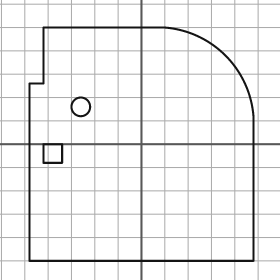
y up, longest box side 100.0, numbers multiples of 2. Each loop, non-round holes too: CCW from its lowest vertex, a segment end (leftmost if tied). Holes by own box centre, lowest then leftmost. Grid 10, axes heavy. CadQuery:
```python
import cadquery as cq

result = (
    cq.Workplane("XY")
    .moveTo(-48.0, -50.0)
    .lineTo(48.0, -50.0)
    .lineTo(48.0, 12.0)
    .threePointArc((36.0, 38.0), (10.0, 50.0))
    .lineTo(-42.0, 50.0)
    .lineTo(-42.0, 26.0)
    .lineTo(-48.0, 26.0)
    .close()
    .moveTo(-42.0, -8.0)
    .lineTo(-34.0, -8.0)
    .lineTo(-34.0, 0.0)
    .lineTo(-42.0, 0.0)
    .close()
    .moveTo(-26.0, 16.0)
    .circle(4.0)
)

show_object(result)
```